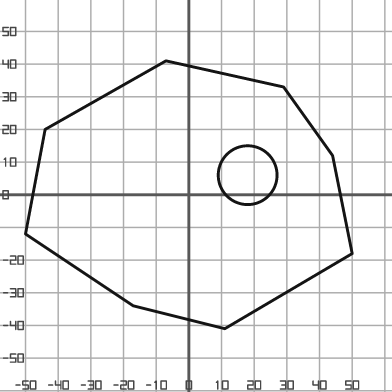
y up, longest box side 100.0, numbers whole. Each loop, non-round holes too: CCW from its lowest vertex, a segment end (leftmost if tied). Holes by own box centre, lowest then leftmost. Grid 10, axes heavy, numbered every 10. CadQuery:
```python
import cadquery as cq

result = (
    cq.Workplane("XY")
    .moveTo(11.0, -41.0)
    .lineTo(50.0, -18.0)
    .lineTo(44.0, 12.0)
    .lineTo(29.0, 33.0)
    .lineTo(-7.0, 41.0)
    .lineTo(-44.0, 20.0)
    .lineTo(-50.0, -12.0)
    .lineTo(-17.0, -34.0)
    .close()
    .moveTo(18.0, 6.0)
    .circle(9.0)
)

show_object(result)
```